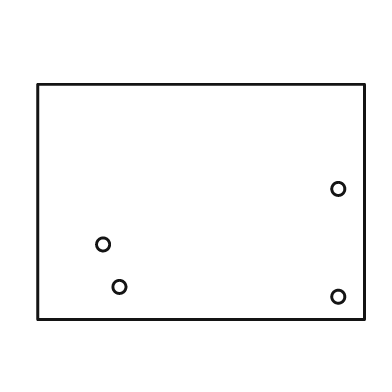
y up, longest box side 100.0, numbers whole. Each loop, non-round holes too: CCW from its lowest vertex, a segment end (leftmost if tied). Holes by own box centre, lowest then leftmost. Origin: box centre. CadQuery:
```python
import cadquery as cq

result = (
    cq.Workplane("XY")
    .moveTo(-50.0, -36.0)
    .lineTo(50.0, -36.0)
    .lineTo(50.0, 36.0)
    .lineTo(-50.0, 36.0)
    .close()
    .moveTo(42.0, -29.0)
    .circle(2.0)
    .moveTo(-25.0, -26.0)
    .circle(2.0)
    .moveTo(-30.0, -13.0)
    .circle(2.0)
    .moveTo(42.0, 4.0)
    .circle(2.0)
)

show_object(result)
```